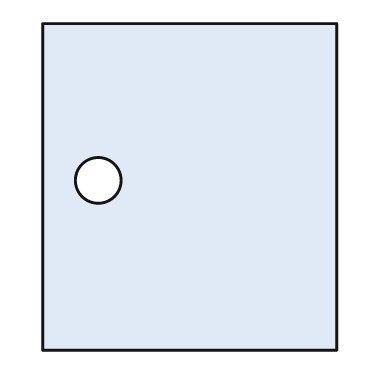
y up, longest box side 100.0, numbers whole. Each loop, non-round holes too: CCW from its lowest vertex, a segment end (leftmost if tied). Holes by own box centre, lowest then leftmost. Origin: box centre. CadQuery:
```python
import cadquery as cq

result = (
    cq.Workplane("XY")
    .moveTo(-45.0, -50.0)
    .lineTo(45.0, -50.0)
    .lineTo(45.0, 50.0)
    .lineTo(-45.0, 50.0)
    .close()
    .moveTo(-28.0, 2.0)
    .circle(7.0)
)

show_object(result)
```